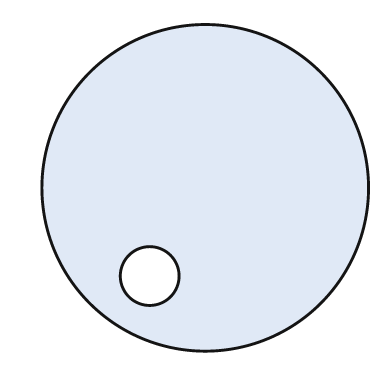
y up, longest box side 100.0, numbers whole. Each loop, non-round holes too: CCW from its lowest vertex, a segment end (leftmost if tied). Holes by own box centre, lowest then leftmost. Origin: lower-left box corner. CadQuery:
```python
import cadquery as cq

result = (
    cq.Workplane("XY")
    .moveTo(50.0, 50.0)
    .circle(50.0)
    .moveTo(33.0, 23.0)
    .circle(9.0)
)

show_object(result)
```